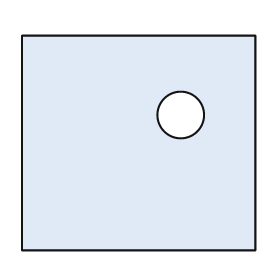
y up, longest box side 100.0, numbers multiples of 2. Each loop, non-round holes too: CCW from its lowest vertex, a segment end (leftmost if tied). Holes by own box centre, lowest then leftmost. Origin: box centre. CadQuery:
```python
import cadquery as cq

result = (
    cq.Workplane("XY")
    .moveTo(-50.0, -46.0)
    .lineTo(50.0, -46.0)
    .lineTo(50.0, 46.0)
    .lineTo(-50.0, 46.0)
    .close()
    .moveTo(18.0, 12.0)
    .circle(10.0)
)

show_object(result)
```